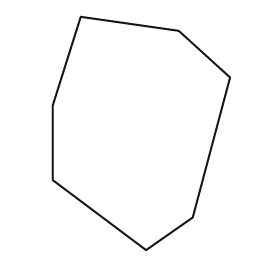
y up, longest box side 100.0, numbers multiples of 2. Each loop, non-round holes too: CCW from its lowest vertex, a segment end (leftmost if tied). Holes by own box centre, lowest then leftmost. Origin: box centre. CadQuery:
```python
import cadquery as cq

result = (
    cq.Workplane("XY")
    .moveTo(2.0, -50.0)
    .lineTo(22.0, -36.0)
    .lineTo(38.0, 24.0)
    .lineTo(16.0, 44.0)
    .lineTo(-26.0, 50.0)
    .lineTo(-38.0, 12.0)
    .lineTo(-38.0, -20.0)
    .close()
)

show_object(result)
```